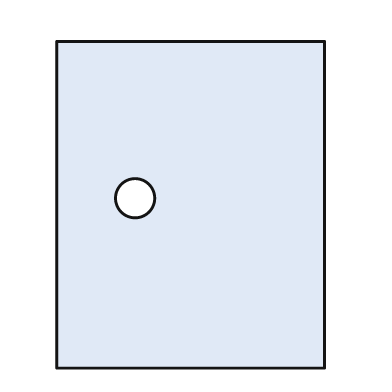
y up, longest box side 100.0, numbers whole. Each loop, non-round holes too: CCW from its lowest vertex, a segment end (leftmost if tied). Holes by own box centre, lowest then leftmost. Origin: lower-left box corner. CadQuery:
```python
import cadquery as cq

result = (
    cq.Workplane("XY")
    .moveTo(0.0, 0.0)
    .lineTo(82.0, 0.0)
    .lineTo(82.0, 100.0)
    .lineTo(0.0, 100.0)
    .close()
    .moveTo(24.0, 52.0)
    .circle(6.0)
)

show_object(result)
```